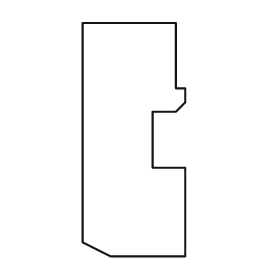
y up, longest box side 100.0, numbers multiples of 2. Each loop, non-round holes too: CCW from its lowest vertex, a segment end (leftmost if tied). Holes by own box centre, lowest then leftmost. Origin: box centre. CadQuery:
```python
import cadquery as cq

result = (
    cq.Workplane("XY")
    .moveTo(-10.0, -50.0)
    .lineTo(22.0, -50.0)
    .lineTo(22.0, -12.0)
    .lineTo(8.0, -12.0)
    .lineTo(8.0, 12.0)
    .lineTo(18.0, 12.0)
    .lineTo(22.0, 16.0)
    .lineTo(22.0, 22.0)
    .lineTo(18.0, 22.0)
    .lineTo(18.0, 50.0)
    .lineTo(-22.0, 50.0)
    .lineTo(-22.0, -44.0)
    .close()
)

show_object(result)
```